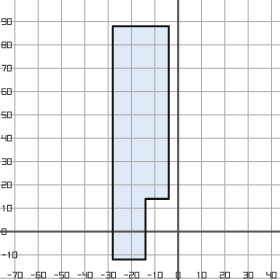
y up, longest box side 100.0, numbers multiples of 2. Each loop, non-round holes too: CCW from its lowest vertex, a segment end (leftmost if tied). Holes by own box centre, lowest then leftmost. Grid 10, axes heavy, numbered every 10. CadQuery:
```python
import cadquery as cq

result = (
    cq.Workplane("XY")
    .moveTo(-28.0, -12.0)
    .lineTo(-14.0, -12.0)
    .lineTo(-14.0, 14.0)
    .lineTo(-4.0, 14.0)
    .lineTo(-4.0, 88.0)
    .lineTo(-28.0, 88.0)
    .close()
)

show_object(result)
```